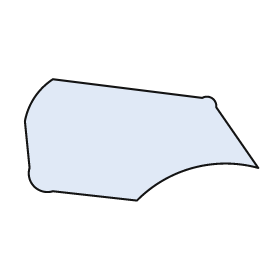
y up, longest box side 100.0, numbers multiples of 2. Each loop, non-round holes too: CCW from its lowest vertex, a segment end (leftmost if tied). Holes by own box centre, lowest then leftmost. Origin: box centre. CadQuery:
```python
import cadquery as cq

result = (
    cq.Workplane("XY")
    .moveTo(-2.0, -26.0)
    .threePointArc((22.0, -12.0), (50.0, -12.0))
    .lineTo(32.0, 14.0)
    .threePointArc((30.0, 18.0), (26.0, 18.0))
    .lineTo(-38.0, 26.0)
    .threePointArc((-46.0, 18.0), (-50.0, 8.0))
    .lineTo(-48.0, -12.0)
    .threePointArc((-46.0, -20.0), (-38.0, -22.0))
    .close()
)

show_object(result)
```